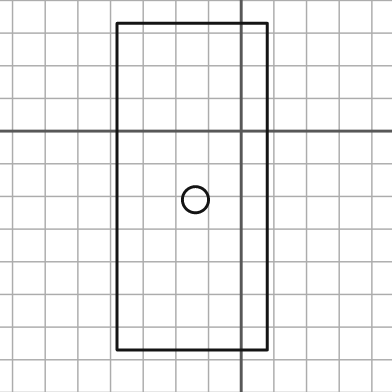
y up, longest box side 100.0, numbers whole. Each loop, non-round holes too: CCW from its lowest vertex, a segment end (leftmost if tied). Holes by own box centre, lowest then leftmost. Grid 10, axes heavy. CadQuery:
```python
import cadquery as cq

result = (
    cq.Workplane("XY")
    .moveTo(-38.0, -67.0)
    .lineTo(8.0, -67.0)
    .lineTo(8.0, 33.0)
    .lineTo(-38.0, 33.0)
    .close()
    .moveTo(-14.0, -21.0)
    .circle(4.0)
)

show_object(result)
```